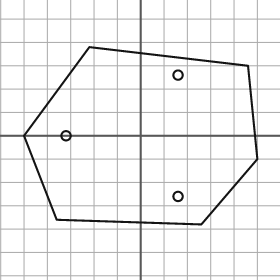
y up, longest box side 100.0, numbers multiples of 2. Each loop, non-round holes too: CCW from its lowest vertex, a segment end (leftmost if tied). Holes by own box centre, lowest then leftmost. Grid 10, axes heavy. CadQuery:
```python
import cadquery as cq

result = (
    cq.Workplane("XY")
    .moveTo(26.0, -38.0)
    .lineTo(50.0, -10.0)
    .lineTo(46.0, 30.0)
    .lineTo(-22.0, 38.0)
    .lineTo(-50.0, 0.0)
    .lineTo(-36.0, -36.0)
    .close()
    .moveTo(16.0, -26.0)
    .circle(2.0)
    .moveTo(-32.0, 0.0)
    .circle(2.0)
    .moveTo(16.0, 26.0)
    .circle(2.0)
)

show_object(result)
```